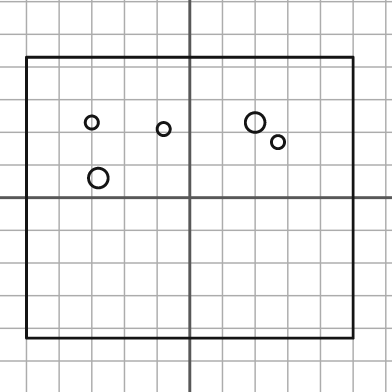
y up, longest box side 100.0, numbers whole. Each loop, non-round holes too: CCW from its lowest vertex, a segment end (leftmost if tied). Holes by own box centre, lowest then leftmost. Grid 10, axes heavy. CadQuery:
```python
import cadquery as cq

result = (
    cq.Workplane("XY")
    .moveTo(-50.0, -43.0)
    .lineTo(50.0, -43.0)
    .lineTo(50.0, 43.0)
    .lineTo(-50.0, 43.0)
    .close()
    .moveTo(-28.0, 6.0)
    .circle(3.0)
    .moveTo(27.0, 17.0)
    .circle(2.0)
    .moveTo(-8.0, 21.0)
    .circle(2.0)
    .moveTo(-30.0, 23.0)
    .circle(2.0)
    .moveTo(20.0, 23.0)
    .circle(3.0)
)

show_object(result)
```